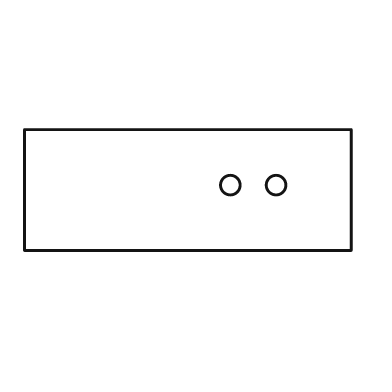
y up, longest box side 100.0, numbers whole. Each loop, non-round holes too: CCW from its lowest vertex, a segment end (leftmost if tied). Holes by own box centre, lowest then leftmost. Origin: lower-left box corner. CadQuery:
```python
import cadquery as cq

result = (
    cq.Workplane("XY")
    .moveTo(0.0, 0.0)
    .lineTo(100.0, 0.0)
    .lineTo(100.0, 37.0)
    .lineTo(0.0, 37.0)
    .close()
    .moveTo(63.0, 20.0)
    .circle(3.0)
    .moveTo(77.0, 20.0)
    .circle(3.0)
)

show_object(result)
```